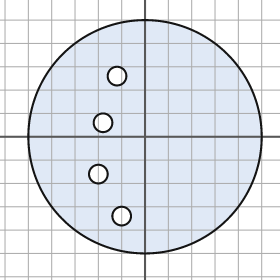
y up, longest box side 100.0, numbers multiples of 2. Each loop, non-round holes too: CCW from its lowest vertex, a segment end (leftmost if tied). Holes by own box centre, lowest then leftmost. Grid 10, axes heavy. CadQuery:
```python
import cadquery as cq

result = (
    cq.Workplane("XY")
    .moveTo(0.0, 0.0)
    .circle(50.0)
    .moveTo(-10.0, -34.0)
    .circle(4.0)
    .moveTo(-20.0, -16.0)
    .circle(4.0)
    .moveTo(-18.0, 6.0)
    .circle(4.0)
    .moveTo(-12.0, 26.0)
    .circle(4.0)
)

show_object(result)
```